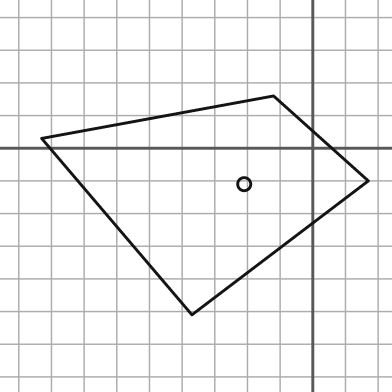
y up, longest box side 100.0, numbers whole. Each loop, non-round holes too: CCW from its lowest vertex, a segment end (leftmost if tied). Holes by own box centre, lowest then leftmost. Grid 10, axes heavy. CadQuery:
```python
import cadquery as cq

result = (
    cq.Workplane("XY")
    .moveTo(-37.0, -51.0)
    .lineTo(17.0, -10.0)
    .lineTo(-12.0, 16.0)
    .lineTo(-83.0, 3.0)
    .close()
    .moveTo(-21.0, -11.0)
    .circle(2.0)
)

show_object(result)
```